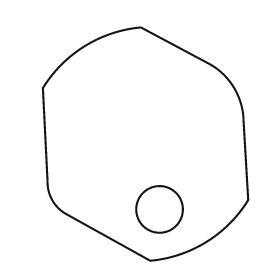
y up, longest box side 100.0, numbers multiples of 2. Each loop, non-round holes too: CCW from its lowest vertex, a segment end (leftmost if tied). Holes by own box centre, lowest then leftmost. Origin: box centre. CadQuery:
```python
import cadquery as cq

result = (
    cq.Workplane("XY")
    .moveTo(2.0, -50.0)
    .threePointArc((26.0, -42.0), (44.0, -24.0))
    .lineTo(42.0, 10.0)
    .threePointArc((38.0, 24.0), (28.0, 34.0))
    .lineTo(-2.0, 50.0)
    .threePointArc((-26.0, 42.0), (-44.0, 24.0))
    .lineTo(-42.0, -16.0)
    .threePointArc((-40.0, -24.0), (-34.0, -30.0))
    .close()
    .moveTo(6.0, -28.0)
    .circle(10.0)
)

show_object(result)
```